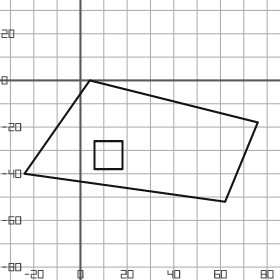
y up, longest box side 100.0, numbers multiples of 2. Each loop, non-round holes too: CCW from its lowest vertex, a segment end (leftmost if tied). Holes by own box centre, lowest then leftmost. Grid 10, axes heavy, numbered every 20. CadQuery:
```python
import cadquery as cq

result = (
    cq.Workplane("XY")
    .moveTo(62.0, -52.0)
    .lineTo(76.0, -18.0)
    .lineTo(4.0, 0.0)
    .lineTo(-24.0, -40.0)
    .close()
    .moveTo(6.0, -38.0)
    .lineTo(18.0, -38.0)
    .lineTo(18.0, -26.0)
    .lineTo(6.0, -26.0)
    .close()
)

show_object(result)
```